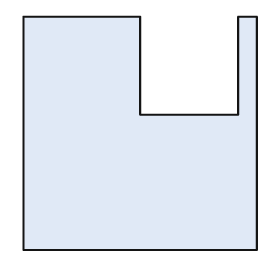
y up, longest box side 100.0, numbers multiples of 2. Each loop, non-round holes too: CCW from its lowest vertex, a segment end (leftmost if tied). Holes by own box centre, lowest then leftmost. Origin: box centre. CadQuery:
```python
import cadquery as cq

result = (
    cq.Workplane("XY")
    .moveTo(-50.0, -50.0)
    .lineTo(50.0, -50.0)
    .lineTo(50.0, 50.0)
    .lineTo(42.0, 50.0)
    .lineTo(42.0, 8.0)
    .lineTo(0.0, 8.0)
    .lineTo(0.0, 50.0)
    .lineTo(-50.0, 50.0)
    .close()
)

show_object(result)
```